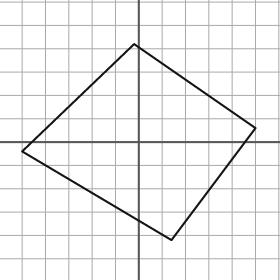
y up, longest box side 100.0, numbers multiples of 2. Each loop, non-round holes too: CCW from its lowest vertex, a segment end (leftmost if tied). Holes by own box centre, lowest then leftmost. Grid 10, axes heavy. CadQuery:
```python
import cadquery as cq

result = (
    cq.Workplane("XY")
    .moveTo(14.0, -42.0)
    .lineTo(50.0, 6.0)
    .lineTo(-2.0, 42.0)
    .lineTo(-50.0, -4.0)
    .close()
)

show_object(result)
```